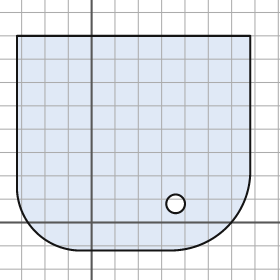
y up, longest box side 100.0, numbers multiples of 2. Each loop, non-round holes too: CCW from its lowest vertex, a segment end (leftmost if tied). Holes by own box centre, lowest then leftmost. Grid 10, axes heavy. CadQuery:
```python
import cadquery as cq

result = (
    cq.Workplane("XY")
    .moveTo(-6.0, -12.0)
    .lineTo(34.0, -12.0)
    .threePointArc((58.0, -2.0), (68.0, 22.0))
    .lineTo(68.0, 80.0)
    .lineTo(-32.0, 80.0)
    .lineTo(-32.0, 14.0)
    .threePointArc((-24.0, -4.0), (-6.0, -12.0))
    .close()
    .moveTo(36.0, 8.0)
    .circle(4.0)
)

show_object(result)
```